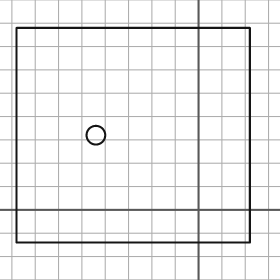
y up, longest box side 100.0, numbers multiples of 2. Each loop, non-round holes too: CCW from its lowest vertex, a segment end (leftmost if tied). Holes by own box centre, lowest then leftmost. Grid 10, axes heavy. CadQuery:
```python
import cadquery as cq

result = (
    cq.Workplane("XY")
    .moveTo(-78.0, -14.0)
    .lineTo(22.0, -14.0)
    .lineTo(22.0, 78.0)
    .lineTo(-78.0, 78.0)
    .close()
    .moveTo(-44.0, 32.0)
    .circle(4.0)
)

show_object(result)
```